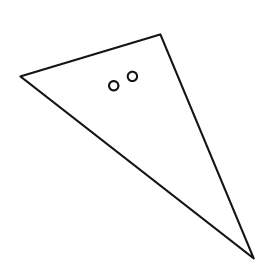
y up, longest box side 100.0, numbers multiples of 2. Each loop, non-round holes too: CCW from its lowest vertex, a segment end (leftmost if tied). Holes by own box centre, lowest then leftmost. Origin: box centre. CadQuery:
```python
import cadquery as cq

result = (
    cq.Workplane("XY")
    .moveTo(50.0, -48.0)
    .lineTo(10.0, 48.0)
    .lineTo(-50.0, 30.0)
    .close()
    .moveTo(-10.0, 26.0)
    .circle(2.0)
    .moveTo(-2.0, 30.0)
    .circle(2.0)
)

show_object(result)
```